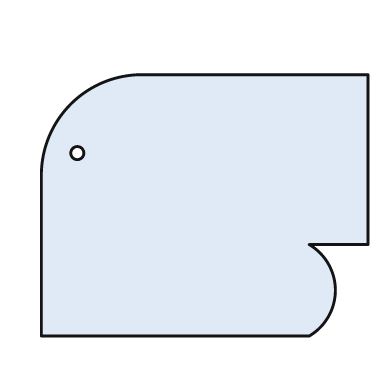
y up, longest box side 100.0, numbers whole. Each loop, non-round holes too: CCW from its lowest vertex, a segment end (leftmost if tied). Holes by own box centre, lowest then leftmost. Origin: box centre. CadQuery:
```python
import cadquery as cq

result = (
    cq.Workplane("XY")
    .moveTo(-50.0, -40.0)
    .lineTo(32.0, -40.0)
    .threePointArc((40.0, -26.0), (32.0, -12.0))
    .lineTo(50.0, -12.0)
    .lineTo(50.0, 40.0)
    .lineTo(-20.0, 40.0)
    .threePointArc((-41.0, 31.0), (-50.0, 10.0))
    .close()
    .moveTo(-39.0, 16.0)
    .circle(2.0)
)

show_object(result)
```